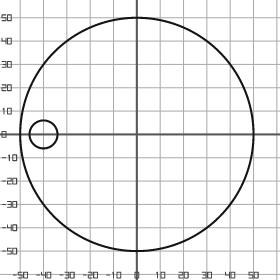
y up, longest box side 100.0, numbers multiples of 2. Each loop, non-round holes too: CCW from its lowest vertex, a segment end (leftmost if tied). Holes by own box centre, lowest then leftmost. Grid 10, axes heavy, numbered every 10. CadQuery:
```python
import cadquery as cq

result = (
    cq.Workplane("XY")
    .moveTo(0.0, 0.0)
    .circle(50.0)
    .moveTo(-40.0, 0.0)
    .circle(6.0)
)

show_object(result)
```